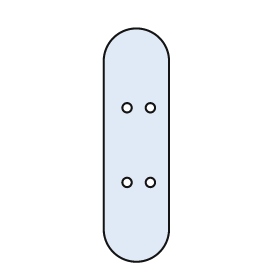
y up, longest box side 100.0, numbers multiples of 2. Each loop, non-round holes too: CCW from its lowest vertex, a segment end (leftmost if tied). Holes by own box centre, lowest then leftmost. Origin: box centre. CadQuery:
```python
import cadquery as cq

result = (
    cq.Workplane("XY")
    .moveTo(-14.0, -36.0)
    .threePointArc((0.0, -50.0), (14.0, -36.0))
    .lineTo(14.0, 36.0)
    .threePointArc((0.0, 50.0), (-14.0, 36.0))
    .close()
    .moveTo(-4.0, -16.0)
    .circle(2.0)
    .moveTo(6.0, -16.0)
    .circle(2.0)
    .moveTo(-4.0, 16.0)
    .circle(2.0)
    .moveTo(6.0, 16.0)
    .circle(2.0)
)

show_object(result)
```